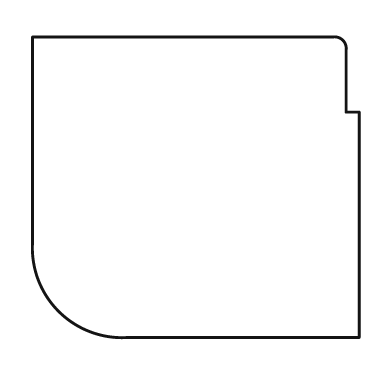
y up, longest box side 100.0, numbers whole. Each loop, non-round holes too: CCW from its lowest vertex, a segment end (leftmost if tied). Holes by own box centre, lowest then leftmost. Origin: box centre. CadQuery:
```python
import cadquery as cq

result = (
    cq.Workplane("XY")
    .moveTo(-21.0, -46.0)
    .lineTo(50.0, -46.0)
    .lineTo(50.0, 23.0)
    .lineTo(46.0, 23.0)
    .lineTo(46.0, 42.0)
    .threePointArc((45.0, 45.0), (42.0, 46.0))
    .lineTo(-50.0, 46.0)
    .lineTo(-50.0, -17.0)
    .threePointArc((-42.0, -38.0), (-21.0, -46.0))
    .close()
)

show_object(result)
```